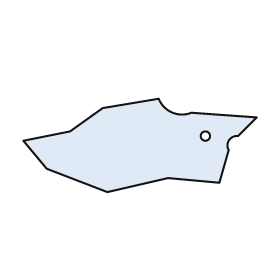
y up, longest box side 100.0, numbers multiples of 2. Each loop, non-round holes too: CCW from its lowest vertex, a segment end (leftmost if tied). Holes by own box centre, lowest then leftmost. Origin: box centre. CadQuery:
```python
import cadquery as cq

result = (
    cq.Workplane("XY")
    .moveTo(-14.0, -20.0)
    .lineTo(12.0, -14.0)
    .lineTo(34.0, -16.0)
    .lineTo(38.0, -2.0)
    .threePointArc((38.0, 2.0), (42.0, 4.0))
    .lineTo(50.0, 12.0)
    .lineTo(22.0, 14.0)
    .threePointArc((14.0, 14.0), (8.0, 20.0))
    .lineTo(-16.0, 16.0)
    .lineTo(-30.0, 6.0)
    .lineTo(-50.0, 2.0)
    .lineTo(-40.0, -10.0)
    .close()
    .moveTo(28.0, 4.0)
    .circle(2.0)
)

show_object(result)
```